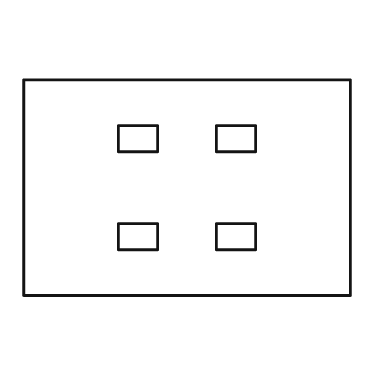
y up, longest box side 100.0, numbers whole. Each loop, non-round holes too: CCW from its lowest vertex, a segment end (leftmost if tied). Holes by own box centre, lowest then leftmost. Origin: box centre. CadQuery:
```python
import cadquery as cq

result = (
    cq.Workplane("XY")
    .moveTo(-50.0, -33.0)
    .lineTo(50.0, -33.0)
    .lineTo(50.0, 33.0)
    .lineTo(-50.0, 33.0)
    .close()
    .moveTo(-21.0, -19.0)
    .lineTo(-9.0, -19.0)
    .lineTo(-9.0, -11.0)
    .lineTo(-21.0, -11.0)
    .close()
    .moveTo(9.0, -19.0)
    .lineTo(21.0, -19.0)
    .lineTo(21.0, -11.0)
    .lineTo(9.0, -11.0)
    .close()
    .moveTo(-21.0, 11.0)
    .lineTo(-9.0, 11.0)
    .lineTo(-9.0, 19.0)
    .lineTo(-21.0, 19.0)
    .close()
    .moveTo(9.0, 11.0)
    .lineTo(21.0, 11.0)
    .lineTo(21.0, 19.0)
    .lineTo(9.0, 19.0)
    .close()
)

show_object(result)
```